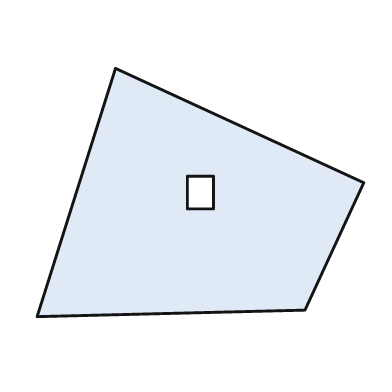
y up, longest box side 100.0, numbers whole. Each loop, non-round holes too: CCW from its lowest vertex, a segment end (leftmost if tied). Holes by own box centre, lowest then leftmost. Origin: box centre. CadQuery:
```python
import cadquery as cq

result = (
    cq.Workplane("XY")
    .moveTo(-50.0, -38.0)
    .lineTo(32.0, -36.0)
    .lineTo(50.0, 3.0)
    .lineTo(-26.0, 38.0)
    .close()
    .moveTo(-4.0, -5.0)
    .lineTo(4.0, -5.0)
    .lineTo(4.0, 5.0)
    .lineTo(-4.0, 5.0)
    .close()
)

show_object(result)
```